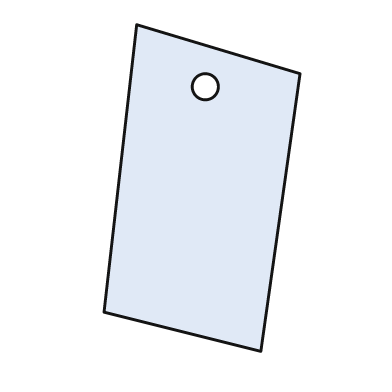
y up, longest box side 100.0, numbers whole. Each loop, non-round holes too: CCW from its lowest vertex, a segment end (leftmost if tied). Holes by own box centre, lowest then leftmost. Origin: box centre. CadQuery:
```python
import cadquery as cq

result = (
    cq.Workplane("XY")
    .moveTo(18.0, -50.0)
    .lineTo(30.0, 35.0)
    .lineTo(-20.0, 50.0)
    .lineTo(-30.0, -38.0)
    .close()
    .moveTo(1.0, 31.0)
    .circle(4.0)
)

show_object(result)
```